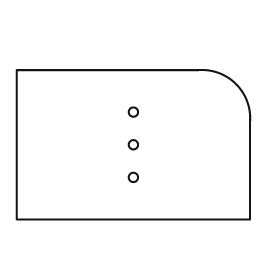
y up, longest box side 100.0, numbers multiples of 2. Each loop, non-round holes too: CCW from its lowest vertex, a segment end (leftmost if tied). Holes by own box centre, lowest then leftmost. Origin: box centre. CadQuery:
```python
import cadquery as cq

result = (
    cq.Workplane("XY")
    .moveTo(-50.0, -32.0)
    .lineTo(50.0, -32.0)
    .lineTo(50.0, 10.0)
    .threePointArc((44.0, 26.0), (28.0, 32.0))
    .lineTo(-50.0, 32.0)
    .close()
    .moveTo(0.0, -14.0)
    .circle(2.0)
    .moveTo(0.0, 0.0)
    .circle(2.0)
    .moveTo(0.0, 14.0)
    .circle(2.0)
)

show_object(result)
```